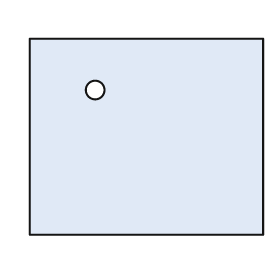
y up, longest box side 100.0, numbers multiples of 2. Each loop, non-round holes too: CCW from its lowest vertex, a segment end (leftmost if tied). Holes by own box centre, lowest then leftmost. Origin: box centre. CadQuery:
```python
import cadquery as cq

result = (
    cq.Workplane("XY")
    .moveTo(-50.0, -42.0)
    .lineTo(50.0, -42.0)
    .lineTo(50.0, 42.0)
    .lineTo(-50.0, 42.0)
    .close()
    .moveTo(-22.0, 20.0)
    .circle(4.0)
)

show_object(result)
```